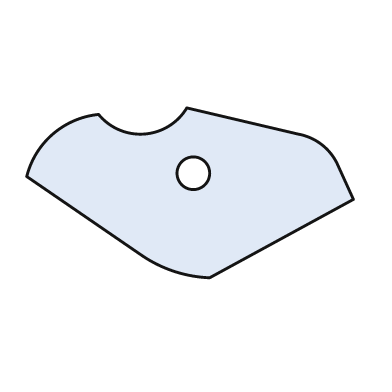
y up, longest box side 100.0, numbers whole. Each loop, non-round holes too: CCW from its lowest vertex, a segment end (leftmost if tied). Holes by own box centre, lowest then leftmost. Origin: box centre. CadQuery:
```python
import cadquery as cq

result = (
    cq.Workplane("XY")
    .moveTo(6.0, -26.0)
    .lineTo(50.0, -2.0)
    .lineTo(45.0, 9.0)
    .threePointArc((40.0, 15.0), (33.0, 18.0))
    .lineTo(-1.0, 26.0)
    .threePointArc((-14.0, 18.0), (-28.0, 24.0))
    .threePointArc((-42.0, 18.0), (-50.0, 5.0))
    .lineTo(-15.0, -19.0)
    .threePointArc((-5.0, -24.0), (6.0, -26.0))
    .close()
    .moveTo(1.0, 6.0)
    .circle(5.0)
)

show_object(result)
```